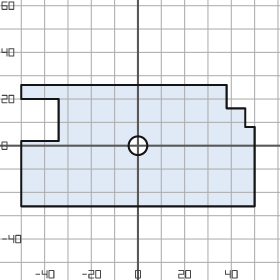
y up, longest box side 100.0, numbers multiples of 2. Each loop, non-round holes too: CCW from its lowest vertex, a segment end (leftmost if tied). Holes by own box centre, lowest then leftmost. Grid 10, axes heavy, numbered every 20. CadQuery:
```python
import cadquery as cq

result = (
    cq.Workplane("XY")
    .moveTo(-50.0, -26.0)
    .lineTo(50.0, -26.0)
    .lineTo(50.0, 8.0)
    .lineTo(46.0, 8.0)
    .lineTo(46.0, 16.0)
    .lineTo(38.0, 16.0)
    .lineTo(38.0, 26.0)
    .lineTo(-50.0, 26.0)
    .lineTo(-50.0, 20.0)
    .lineTo(-34.0, 20.0)
    .lineTo(-34.0, 2.0)
    .lineTo(-50.0, 2.0)
    .close()
    .moveTo(0.0, 0.0)
    .circle(4.0)
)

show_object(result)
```